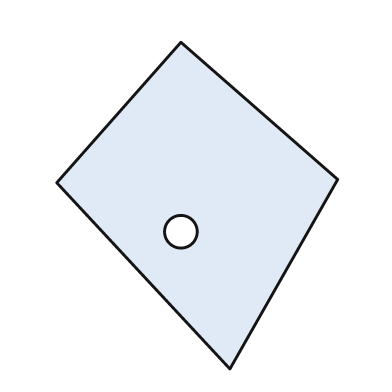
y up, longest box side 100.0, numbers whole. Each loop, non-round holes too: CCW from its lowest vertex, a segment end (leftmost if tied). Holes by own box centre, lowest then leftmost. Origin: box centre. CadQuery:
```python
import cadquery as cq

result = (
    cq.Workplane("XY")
    .moveTo(10.0, -50.0)
    .lineTo(43.0, 8.0)
    .lineTo(-5.0, 50.0)
    .lineTo(-43.0, 7.0)
    .close()
    .moveTo(-5.0, -8.0)
    .circle(5.0)
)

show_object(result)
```